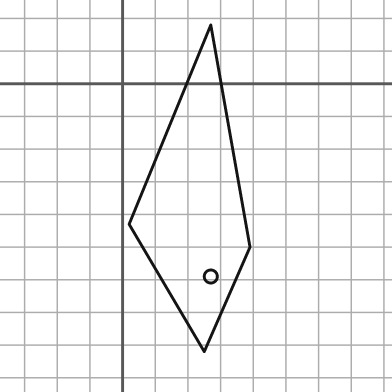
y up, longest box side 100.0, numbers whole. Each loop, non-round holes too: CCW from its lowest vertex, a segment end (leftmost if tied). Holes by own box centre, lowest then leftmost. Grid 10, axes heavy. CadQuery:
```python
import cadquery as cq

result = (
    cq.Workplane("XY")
    .moveTo(25.0, -82.0)
    .lineTo(39.0, -50.0)
    .lineTo(27.0, 18.0)
    .lineTo(2.0, -43.0)
    .close()
    .moveTo(27.0, -59.0)
    .circle(2.0)
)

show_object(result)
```